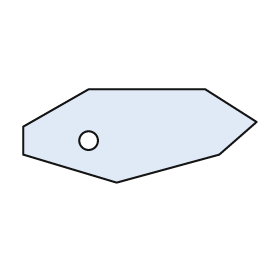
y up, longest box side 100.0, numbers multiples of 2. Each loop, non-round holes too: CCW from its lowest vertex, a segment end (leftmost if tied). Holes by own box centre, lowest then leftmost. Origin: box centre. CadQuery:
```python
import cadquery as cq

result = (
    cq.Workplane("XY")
    .moveTo(-10.0, -20.0)
    .lineTo(34.0, -8.0)
    .lineTo(50.0, 6.0)
    .lineTo(28.0, 20.0)
    .lineTo(-22.0, 20.0)
    .lineTo(-50.0, 4.0)
    .lineTo(-50.0, -8.0)
    .close()
    .moveTo(-22.0, -2.0)
    .circle(4.0)
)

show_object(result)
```